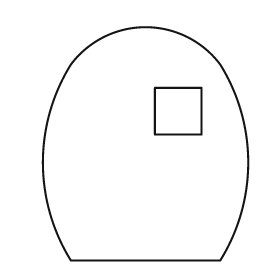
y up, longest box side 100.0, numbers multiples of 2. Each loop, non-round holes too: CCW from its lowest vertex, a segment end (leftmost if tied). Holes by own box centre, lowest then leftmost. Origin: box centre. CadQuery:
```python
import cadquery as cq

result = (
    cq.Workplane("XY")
    .moveTo(-32.0, -50.0)
    .lineTo(32.0, -50.0)
    .threePointArc((44.0, -8.0), (32.0, 34.0))
    .threePointArc((0.0, 50.0), (-32.0, 34.0))
    .threePointArc((-44.0, -8.0), (-32.0, -50.0))
    .close()
    .moveTo(4.0, 4.0)
    .lineTo(24.0, 4.0)
    .lineTo(24.0, 24.0)
    .lineTo(4.0, 24.0)
    .close()
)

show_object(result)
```